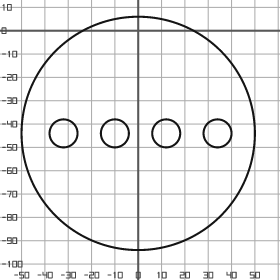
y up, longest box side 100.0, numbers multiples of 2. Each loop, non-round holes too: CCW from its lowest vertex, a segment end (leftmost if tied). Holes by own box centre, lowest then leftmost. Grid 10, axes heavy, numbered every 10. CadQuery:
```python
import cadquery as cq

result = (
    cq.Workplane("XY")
    .moveTo(0.0, -44.0)
    .circle(50.0)
    .moveTo(-32.0, -44.0)
    .circle(6.0)
    .moveTo(-10.0, -44.0)
    .circle(6.0)
    .moveTo(12.0, -44.0)
    .circle(6.0)
    .moveTo(34.0, -44.0)
    .circle(6.0)
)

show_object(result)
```